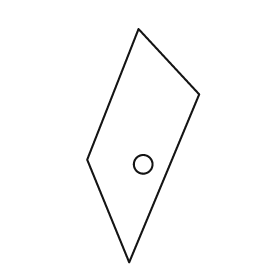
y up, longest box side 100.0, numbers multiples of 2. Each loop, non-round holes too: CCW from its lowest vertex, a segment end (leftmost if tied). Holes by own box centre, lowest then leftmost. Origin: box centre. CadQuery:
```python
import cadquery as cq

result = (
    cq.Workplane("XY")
    .moveTo(-6.0, -50.0)
    .lineTo(24.0, 22.0)
    .lineTo(-2.0, 50.0)
    .lineTo(-24.0, -6.0)
    .close()
    .moveTo(0.0, -8.0)
    .circle(4.0)
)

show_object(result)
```